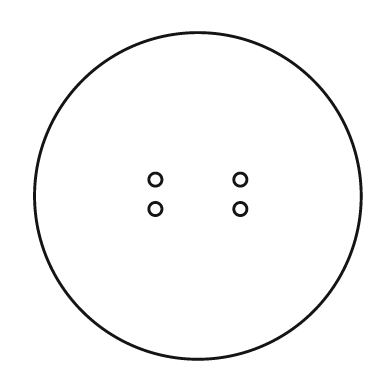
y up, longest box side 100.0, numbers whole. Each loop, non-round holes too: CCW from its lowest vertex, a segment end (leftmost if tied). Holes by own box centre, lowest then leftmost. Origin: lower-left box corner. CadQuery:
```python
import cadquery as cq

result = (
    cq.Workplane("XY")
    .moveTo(50.0, 50.0)
    .circle(50.0)
    .moveTo(37.0, 46.0)
    .circle(2.0)
    .moveTo(63.0, 46.0)
    .circle(2.0)
    .moveTo(37.0, 55.0)
    .circle(2.0)
    .moveTo(63.0, 55.0)
    .circle(2.0)
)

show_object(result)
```